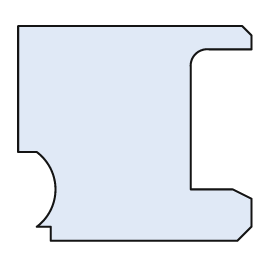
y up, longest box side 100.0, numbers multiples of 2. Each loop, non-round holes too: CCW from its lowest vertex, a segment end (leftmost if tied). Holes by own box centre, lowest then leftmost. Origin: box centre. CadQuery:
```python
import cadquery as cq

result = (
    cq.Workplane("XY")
    .moveTo(-36.0, -46.0)
    .lineTo(44.0, -46.0)
    .lineTo(50.0, -40.0)
    .lineTo(50.0, -28.0)
    .lineTo(42.0, -24.0)
    .lineTo(24.0, -24.0)
    .lineTo(24.0, 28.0)
    .threePointArc((26.0, 34.0), (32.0, 36.0))
    .lineTo(50.0, 36.0)
    .lineTo(50.0, 42.0)
    .lineTo(46.0, 46.0)
    .lineTo(-50.0, 46.0)
    .lineTo(-50.0, -8.0)
    .lineTo(-42.0, -8.0)
    .threePointArc((-34.0, -24.0), (-42.0, -40.0))
    .lineTo(-36.0, -40.0)
    .close()
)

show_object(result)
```